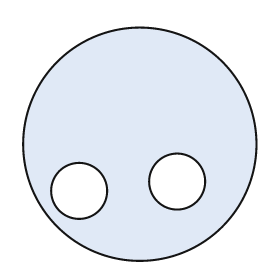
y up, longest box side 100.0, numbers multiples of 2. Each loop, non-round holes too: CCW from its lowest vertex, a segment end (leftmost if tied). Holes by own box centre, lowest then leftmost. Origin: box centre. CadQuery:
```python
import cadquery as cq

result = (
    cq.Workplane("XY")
    .moveTo(0.0, 0.0)
    .circle(50.0)
    .moveTo(-26.0, -20.0)
    .circle(12.0)
    .moveTo(16.0, -16.0)
    .circle(12.0)
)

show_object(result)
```